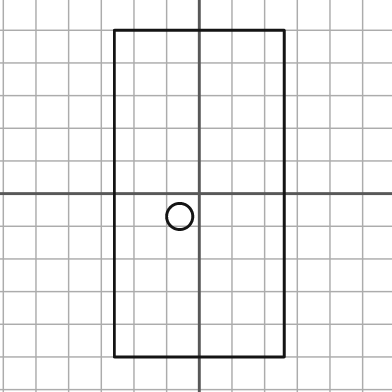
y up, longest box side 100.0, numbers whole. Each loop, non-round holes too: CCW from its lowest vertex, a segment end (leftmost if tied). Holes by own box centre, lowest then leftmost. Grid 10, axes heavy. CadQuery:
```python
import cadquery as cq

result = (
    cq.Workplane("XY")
    .moveTo(-26.0, -50.0)
    .lineTo(26.0, -50.0)
    .lineTo(26.0, 50.0)
    .lineTo(-26.0, 50.0)
    .close()
    .moveTo(-6.0, -7.0)
    .circle(4.0)
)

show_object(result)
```